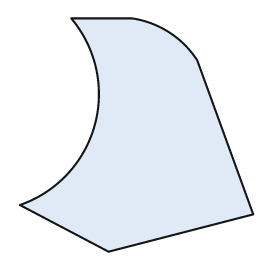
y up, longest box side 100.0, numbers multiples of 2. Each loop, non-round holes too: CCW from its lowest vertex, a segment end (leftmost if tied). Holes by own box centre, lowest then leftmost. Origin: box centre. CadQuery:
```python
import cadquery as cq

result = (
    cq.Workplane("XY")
    .moveTo(-12.0, -50.0)
    .lineTo(50.0, -34.0)
    .lineTo(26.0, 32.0)
    .threePointArc((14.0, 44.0), (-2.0, 50.0))
    .lineTo(-28.0, 50.0)
    .threePointArc((-18.0, 4.0), (-50.0, -30.0))
    .close()
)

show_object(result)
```